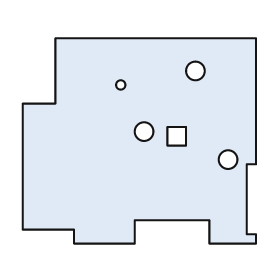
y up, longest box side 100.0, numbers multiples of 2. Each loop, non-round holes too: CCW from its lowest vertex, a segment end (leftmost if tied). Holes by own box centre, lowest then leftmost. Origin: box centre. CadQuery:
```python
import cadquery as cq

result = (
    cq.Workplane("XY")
    .moveTo(-28.0, -44.0)
    .lineTo(-2.0, -44.0)
    .lineTo(-2.0, -34.0)
    .lineTo(30.0, -34.0)
    .lineTo(30.0, -44.0)
    .lineTo(50.0, -44.0)
    .lineTo(50.0, -40.0)
    .lineTo(46.0, -40.0)
    .lineTo(46.0, -10.0)
    .lineTo(50.0, -10.0)
    .lineTo(50.0, 44.0)
    .lineTo(-36.0, 44.0)
    .lineTo(-36.0, 16.0)
    .lineTo(-50.0, 16.0)
    .lineTo(-50.0, -38.0)
    .lineTo(-28.0, -38.0)
    .close()
    .moveTo(38.0, -8.0)
    .circle(4.0)
    .moveTo(12.0, -2.0)
    .lineTo(20.0, -2.0)
    .lineTo(20.0, 6.0)
    .lineTo(12.0, 6.0)
    .close()
    .moveTo(2.0, 4.0)
    .circle(4.0)
    .moveTo(-8.0, 24.0)
    .circle(2.0)
    .moveTo(24.0, 30.0)
    .circle(4.0)
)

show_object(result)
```